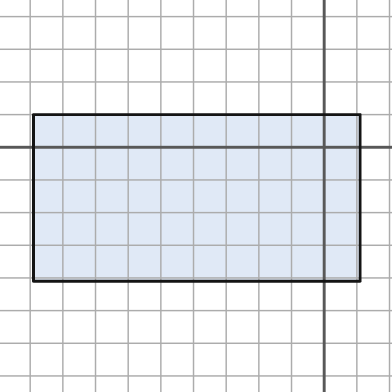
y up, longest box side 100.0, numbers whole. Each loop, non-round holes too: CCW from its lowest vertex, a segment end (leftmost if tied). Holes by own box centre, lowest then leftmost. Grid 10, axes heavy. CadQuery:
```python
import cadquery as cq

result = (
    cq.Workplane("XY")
    .moveTo(-89.0, -41.0)
    .lineTo(11.0, -41.0)
    .lineTo(11.0, 10.0)
    .lineTo(-89.0, 10.0)
    .close()
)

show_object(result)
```